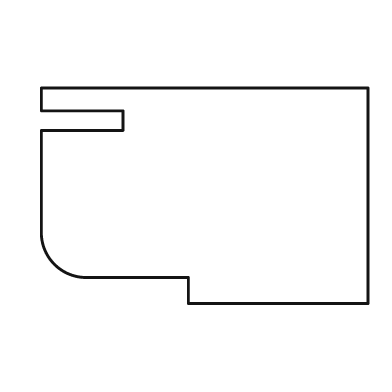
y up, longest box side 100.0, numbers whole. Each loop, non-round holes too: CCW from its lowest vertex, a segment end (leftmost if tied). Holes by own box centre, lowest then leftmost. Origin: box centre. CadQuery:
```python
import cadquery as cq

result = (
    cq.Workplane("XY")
    .moveTo(-5.0, -33.0)
    .lineTo(50.0, -33.0)
    .lineTo(50.0, 33.0)
    .lineTo(-50.0, 33.0)
    .lineTo(-50.0, 26.0)
    .lineTo(-25.0, 26.0)
    .lineTo(-25.0, 20.0)
    .lineTo(-50.0, 20.0)
    .lineTo(-50.0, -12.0)
    .threePointArc((-46.0, -21.0), (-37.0, -25.0))
    .lineTo(-5.0, -25.0)
    .close()
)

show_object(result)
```